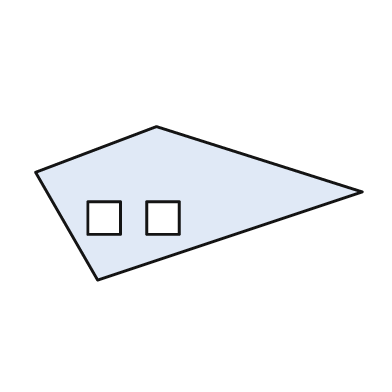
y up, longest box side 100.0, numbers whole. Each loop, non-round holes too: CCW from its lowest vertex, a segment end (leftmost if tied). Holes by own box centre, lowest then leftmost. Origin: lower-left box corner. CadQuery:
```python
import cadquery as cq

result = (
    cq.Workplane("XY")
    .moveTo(19.0, 0.0)
    .lineTo(100.0, 27.0)
    .lineTo(37.0, 47.0)
    .lineTo(0.0, 33.0)
    .close()
    .moveTo(16.0, 14.0)
    .lineTo(26.0, 14.0)
    .lineTo(26.0, 24.0)
    .lineTo(16.0, 24.0)
    .close()
    .moveTo(34.0, 14.0)
    .lineTo(44.0, 14.0)
    .lineTo(44.0, 24.0)
    .lineTo(34.0, 24.0)
    .close()
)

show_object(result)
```